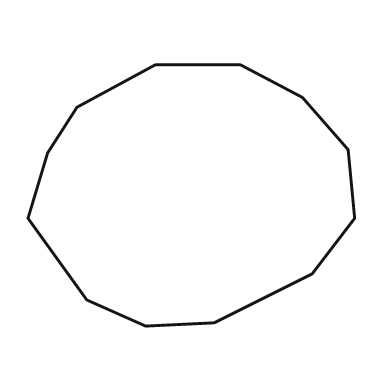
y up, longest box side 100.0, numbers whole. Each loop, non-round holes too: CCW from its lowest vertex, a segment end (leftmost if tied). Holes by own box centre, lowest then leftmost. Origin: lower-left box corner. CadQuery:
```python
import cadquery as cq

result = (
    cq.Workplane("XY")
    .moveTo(36.0, 0.0)
    .lineTo(57.0, 1.0)
    .lineTo(87.0, 16.0)
    .lineTo(100.0, 33.0)
    .lineTo(98.0, 54.0)
    .lineTo(84.0, 70.0)
    .lineTo(65.0, 80.0)
    .lineTo(39.0, 80.0)
    .lineTo(15.0, 67.0)
    .lineTo(6.0, 53.0)
    .lineTo(0.0, 33.0)
    .lineTo(18.0, 8.0)
    .close()
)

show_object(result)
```